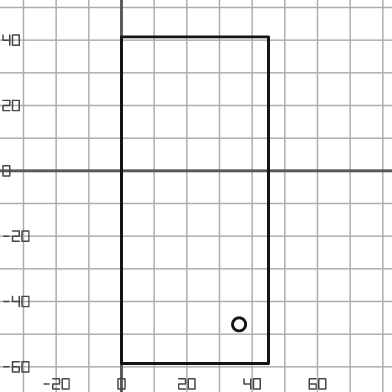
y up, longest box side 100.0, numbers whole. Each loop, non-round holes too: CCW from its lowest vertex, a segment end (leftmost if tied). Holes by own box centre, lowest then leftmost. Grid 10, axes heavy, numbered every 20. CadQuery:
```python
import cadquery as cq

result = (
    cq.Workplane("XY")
    .moveTo(0.0, -59.0)
    .lineTo(45.0, -59.0)
    .lineTo(45.0, 41.0)
    .lineTo(0.0, 41.0)
    .close()
    .moveTo(36.0, -47.0)
    .circle(2.0)
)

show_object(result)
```